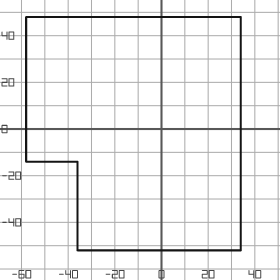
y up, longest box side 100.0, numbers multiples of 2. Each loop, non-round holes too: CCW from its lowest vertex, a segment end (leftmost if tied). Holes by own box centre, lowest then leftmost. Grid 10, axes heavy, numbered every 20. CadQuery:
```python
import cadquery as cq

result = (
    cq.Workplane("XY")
    .moveTo(-36.0, -52.0)
    .lineTo(34.0, -52.0)
    .lineTo(34.0, 48.0)
    .lineTo(-58.0, 48.0)
    .lineTo(-58.0, -14.0)
    .lineTo(-36.0, -14.0)
    .close()
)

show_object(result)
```